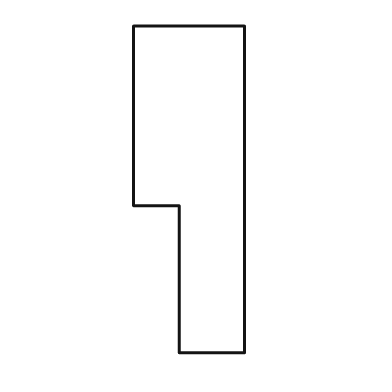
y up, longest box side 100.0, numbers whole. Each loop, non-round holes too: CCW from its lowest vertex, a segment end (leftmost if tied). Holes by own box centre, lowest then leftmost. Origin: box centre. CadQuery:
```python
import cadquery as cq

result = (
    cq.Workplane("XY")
    .moveTo(-3.0, -50.0)
    .lineTo(17.0, -50.0)
    .lineTo(17.0, 50.0)
    .lineTo(-17.0, 50.0)
    .lineTo(-17.0, -5.0)
    .lineTo(-3.0, -5.0)
    .close()
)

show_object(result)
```